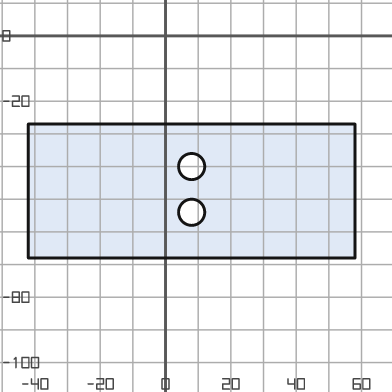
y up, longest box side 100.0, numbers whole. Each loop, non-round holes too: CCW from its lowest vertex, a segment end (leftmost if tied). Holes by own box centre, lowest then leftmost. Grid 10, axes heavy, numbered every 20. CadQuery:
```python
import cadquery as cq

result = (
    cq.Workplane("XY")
    .moveTo(-42.0, -68.0)
    .lineTo(58.0, -68.0)
    .lineTo(58.0, -27.0)
    .lineTo(-42.0, -27.0)
    .close()
    .moveTo(8.0, -54.0)
    .circle(4.0)
    .moveTo(8.0, -40.0)
    .circle(4.0)
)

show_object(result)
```